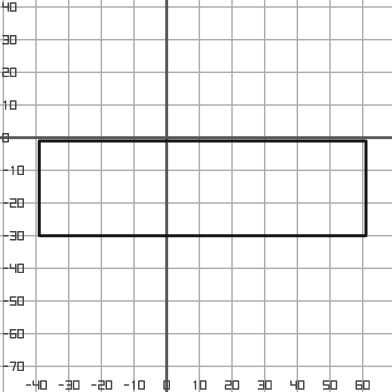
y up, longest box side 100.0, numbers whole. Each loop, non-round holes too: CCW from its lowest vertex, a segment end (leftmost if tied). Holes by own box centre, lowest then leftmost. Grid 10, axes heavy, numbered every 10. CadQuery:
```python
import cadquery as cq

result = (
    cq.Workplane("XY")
    .moveTo(-39.0, -30.0)
    .lineTo(61.0, -30.0)
    .lineTo(61.0, -1.0)
    .lineTo(-39.0, -1.0)
    .close()
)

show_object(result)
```